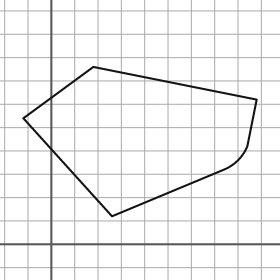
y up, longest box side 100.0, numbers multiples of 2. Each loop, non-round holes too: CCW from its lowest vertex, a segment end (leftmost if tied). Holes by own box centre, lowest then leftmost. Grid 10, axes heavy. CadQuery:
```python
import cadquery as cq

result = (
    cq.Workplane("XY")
    .moveTo(26.0, 12.0)
    .lineTo(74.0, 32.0)
    .threePointArc((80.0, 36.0), (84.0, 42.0))
    .lineTo(88.0, 62.0)
    .lineTo(18.0, 76.0)
    .lineTo(-12.0, 54.0)
    .close()
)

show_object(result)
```